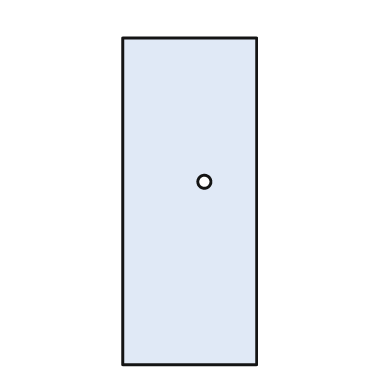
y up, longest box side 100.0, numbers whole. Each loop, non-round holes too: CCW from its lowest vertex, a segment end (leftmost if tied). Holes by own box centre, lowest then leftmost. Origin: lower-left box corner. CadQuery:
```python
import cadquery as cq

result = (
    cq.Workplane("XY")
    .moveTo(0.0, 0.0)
    .lineTo(41.0, 0.0)
    .lineTo(41.0, 100.0)
    .lineTo(0.0, 100.0)
    .close()
    .moveTo(25.0, 56.0)
    .circle(2.0)
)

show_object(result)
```